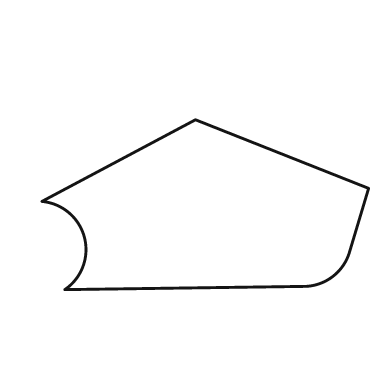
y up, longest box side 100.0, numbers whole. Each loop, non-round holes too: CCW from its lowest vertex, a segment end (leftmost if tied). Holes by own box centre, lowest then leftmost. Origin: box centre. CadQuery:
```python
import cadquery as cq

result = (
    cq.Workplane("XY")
    .moveTo(-43.0, -26.0)
    .lineTo(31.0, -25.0)
    .threePointArc((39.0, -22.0), (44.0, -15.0))
    .lineTo(50.0, 5.0)
    .lineTo(-3.0, 26.0)
    .lineTo(-50.0, 1.0)
    .threePointArc((-37.0, -10.0), (-43.0, -26.0))
    .close()
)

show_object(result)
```